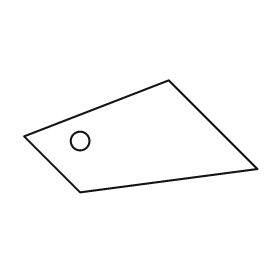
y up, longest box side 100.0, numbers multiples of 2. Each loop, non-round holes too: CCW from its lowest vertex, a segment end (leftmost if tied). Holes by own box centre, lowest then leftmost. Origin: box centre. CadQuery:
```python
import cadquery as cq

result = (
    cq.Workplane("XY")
    .moveTo(-26.0, -24.0)
    .lineTo(50.0, -14.0)
    .lineTo(12.0, 24.0)
    .lineTo(-50.0, 0.0)
    .close()
    .moveTo(-26.0, -2.0)
    .circle(4.0)
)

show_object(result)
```